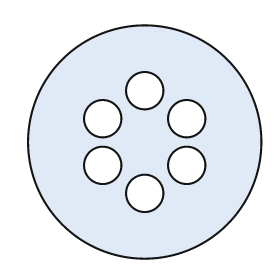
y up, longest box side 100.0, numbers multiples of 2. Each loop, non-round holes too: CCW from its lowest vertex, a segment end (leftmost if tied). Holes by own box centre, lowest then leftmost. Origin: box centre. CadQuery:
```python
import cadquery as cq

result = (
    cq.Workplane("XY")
    .moveTo(0.0, 0.0)
    .circle(50.0)
    .moveTo(0.0, -22.0)
    .circle(8.0)
    .moveTo(-18.0, -10.0)
    .circle(8.0)
    .moveTo(18.0, -10.0)
    .circle(8.0)
    .moveTo(-18.0, 10.0)
    .circle(8.0)
    .moveTo(18.0, 10.0)
    .circle(8.0)
    .moveTo(0.0, 22.0)
    .circle(8.0)
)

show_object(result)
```